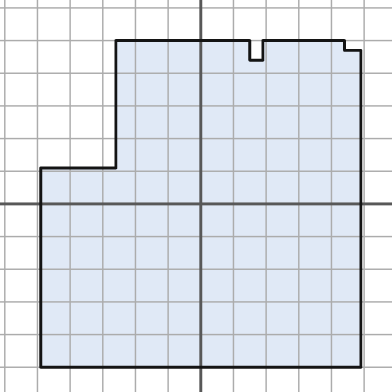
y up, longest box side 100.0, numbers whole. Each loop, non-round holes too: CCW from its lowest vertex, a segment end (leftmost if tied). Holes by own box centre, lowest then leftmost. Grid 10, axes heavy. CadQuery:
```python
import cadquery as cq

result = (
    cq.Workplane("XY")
    .moveTo(-49.0, -50.0)
    .lineTo(49.0, -50.0)
    .lineTo(49.0, 47.0)
    .lineTo(44.0, 47.0)
    .lineTo(44.0, 50.0)
    .lineTo(19.0, 50.0)
    .lineTo(19.0, 44.0)
    .lineTo(15.0, 44.0)
    .lineTo(15.0, 50.0)
    .lineTo(-26.0, 50.0)
    .lineTo(-26.0, 11.0)
    .lineTo(-49.0, 11.0)
    .close()
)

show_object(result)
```